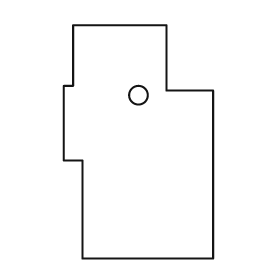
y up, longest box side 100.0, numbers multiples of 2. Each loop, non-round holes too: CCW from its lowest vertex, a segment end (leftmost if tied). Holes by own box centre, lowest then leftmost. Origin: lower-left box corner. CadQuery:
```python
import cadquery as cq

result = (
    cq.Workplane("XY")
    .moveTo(8.0, 0.0)
    .lineTo(64.0, 0.0)
    .lineTo(64.0, 72.0)
    .lineTo(44.0, 72.0)
    .lineTo(44.0, 100.0)
    .lineTo(4.0, 100.0)
    .lineTo(4.0, 74.0)
    .lineTo(0.0, 74.0)
    .lineTo(0.0, 42.0)
    .lineTo(8.0, 42.0)
    .close()
    .moveTo(32.0, 70.0)
    .circle(4.0)
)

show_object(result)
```